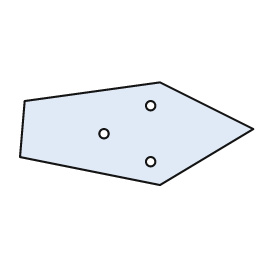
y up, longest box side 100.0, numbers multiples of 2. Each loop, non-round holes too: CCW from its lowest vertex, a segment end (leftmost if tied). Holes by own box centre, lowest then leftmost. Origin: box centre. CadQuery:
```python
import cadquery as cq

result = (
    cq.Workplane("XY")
    .moveTo(10.0, -22.0)
    .lineTo(50.0, 2.0)
    .lineTo(10.0, 22.0)
    .lineTo(-48.0, 14.0)
    .lineTo(-50.0, -10.0)
    .close()
    .moveTo(6.0, -12.0)
    .circle(2.0)
    .moveTo(-14.0, 0.0)
    .circle(2.0)
    .moveTo(6.0, 12.0)
    .circle(2.0)
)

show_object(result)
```